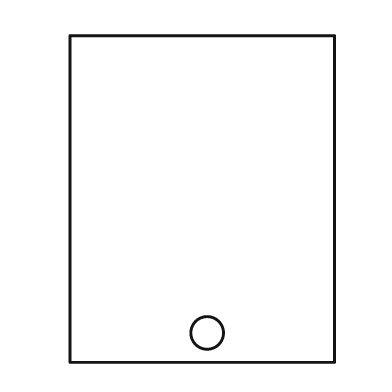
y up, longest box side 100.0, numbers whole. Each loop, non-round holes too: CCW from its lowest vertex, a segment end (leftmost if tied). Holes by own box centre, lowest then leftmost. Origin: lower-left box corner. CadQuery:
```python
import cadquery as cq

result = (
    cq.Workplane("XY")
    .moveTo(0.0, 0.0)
    .lineTo(81.0, 0.0)
    .lineTo(81.0, 100.0)
    .lineTo(0.0, 100.0)
    .close()
    .moveTo(42.0, 9.0)
    .circle(5.0)
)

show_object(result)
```